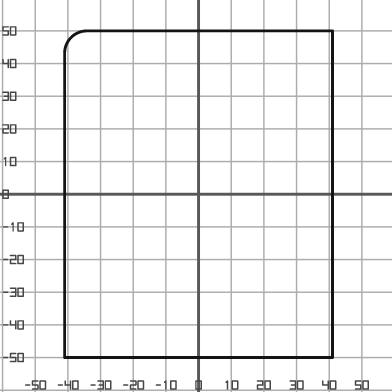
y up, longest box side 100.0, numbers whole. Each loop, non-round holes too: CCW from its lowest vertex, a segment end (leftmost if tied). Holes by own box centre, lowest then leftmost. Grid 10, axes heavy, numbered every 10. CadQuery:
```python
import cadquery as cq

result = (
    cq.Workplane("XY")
    .moveTo(-41.0, -50.0)
    .lineTo(41.0, -50.0)
    .lineTo(41.0, 50.0)
    .lineTo(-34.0, 50.0)
    .threePointArc((-39.0, 48.0), (-41.0, 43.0))
    .close()
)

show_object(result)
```